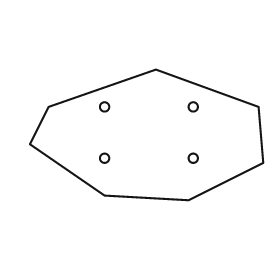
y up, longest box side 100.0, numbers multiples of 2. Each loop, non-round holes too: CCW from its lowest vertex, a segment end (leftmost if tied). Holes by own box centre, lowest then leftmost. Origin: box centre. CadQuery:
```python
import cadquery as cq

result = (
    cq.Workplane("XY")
    .moveTo(18.0, -28.0)
    .lineTo(50.0, -12.0)
    .lineTo(48.0, 12.0)
    .lineTo(4.0, 28.0)
    .lineTo(-42.0, 12.0)
    .lineTo(-50.0, -4.0)
    .lineTo(-18.0, -26.0)
    .close()
    .moveTo(-18.0, -10.0)
    .circle(2.0)
    .moveTo(20.0, -10.0)
    .circle(2.0)
    .moveTo(-18.0, 12.0)
    .circle(2.0)
    .moveTo(20.0, 12.0)
    .circle(2.0)
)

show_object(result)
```